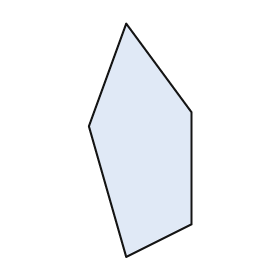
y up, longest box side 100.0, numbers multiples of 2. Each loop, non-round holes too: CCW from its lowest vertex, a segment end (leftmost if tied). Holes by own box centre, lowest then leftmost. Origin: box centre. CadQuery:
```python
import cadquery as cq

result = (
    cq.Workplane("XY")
    .moveTo(-6.0, -50.0)
    .lineTo(22.0, -36.0)
    .lineTo(22.0, 12.0)
    .lineTo(-6.0, 50.0)
    .lineTo(-22.0, 6.0)
    .close()
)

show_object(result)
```